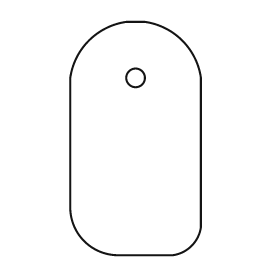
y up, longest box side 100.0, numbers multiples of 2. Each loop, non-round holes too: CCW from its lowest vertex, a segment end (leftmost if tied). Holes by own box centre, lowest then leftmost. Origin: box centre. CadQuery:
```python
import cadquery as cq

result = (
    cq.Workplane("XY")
    .moveTo(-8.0, -50.0)
    .lineTo(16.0, -50.0)
    .threePointArc((24.0, -46.0), (28.0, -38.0))
    .lineTo(28.0, 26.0)
    .threePointArc((20.0, 42.0), (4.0, 50.0))
    .lineTo(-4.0, 50.0)
    .threePointArc((-20.0, 42.0), (-28.0, 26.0))
    .lineTo(-28.0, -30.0)
    .threePointArc((-22.0, -44.0), (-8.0, -50.0))
    .close()
    .moveTo(0.0, 26.0)
    .circle(4.0)
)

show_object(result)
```